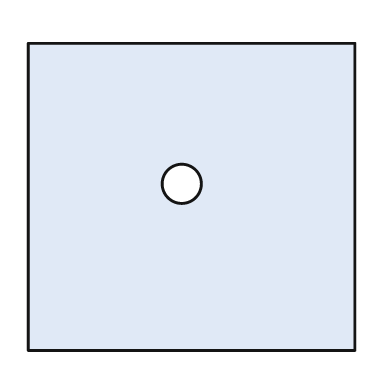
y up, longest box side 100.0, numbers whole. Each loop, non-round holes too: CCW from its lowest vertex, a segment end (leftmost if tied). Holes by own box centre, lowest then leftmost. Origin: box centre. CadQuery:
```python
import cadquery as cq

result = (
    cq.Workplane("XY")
    .moveTo(-50.0, -47.0)
    .lineTo(50.0, -47.0)
    .lineTo(50.0, 47.0)
    .lineTo(-50.0, 47.0)
    .close()
    .moveTo(-3.0, 4.0)
    .circle(6.0)
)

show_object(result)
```